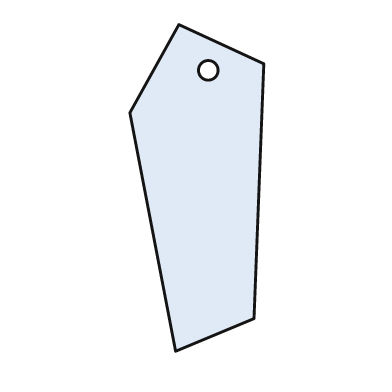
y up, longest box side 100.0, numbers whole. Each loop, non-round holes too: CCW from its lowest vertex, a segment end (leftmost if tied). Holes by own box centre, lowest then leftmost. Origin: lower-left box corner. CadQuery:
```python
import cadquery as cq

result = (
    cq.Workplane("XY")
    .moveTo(14.0, 0.0)
    .lineTo(38.0, 10.0)
    .lineTo(41.0, 88.0)
    .lineTo(15.0, 100.0)
    .lineTo(0.0, 73.0)
    .close()
    .moveTo(24.0, 86.0)
    .circle(3.0)
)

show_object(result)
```